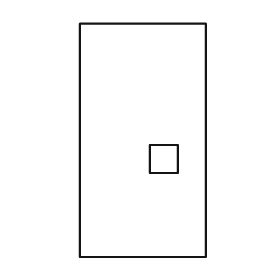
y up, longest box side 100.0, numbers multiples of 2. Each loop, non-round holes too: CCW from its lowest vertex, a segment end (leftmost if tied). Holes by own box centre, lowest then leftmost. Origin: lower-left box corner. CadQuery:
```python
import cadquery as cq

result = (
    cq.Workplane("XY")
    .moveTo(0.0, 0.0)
    .lineTo(54.0, 0.0)
    .lineTo(54.0, 100.0)
    .lineTo(0.0, 100.0)
    .close()
    .moveTo(30.0, 36.0)
    .lineTo(42.0, 36.0)
    .lineTo(42.0, 48.0)
    .lineTo(30.0, 48.0)
    .close()
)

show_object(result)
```